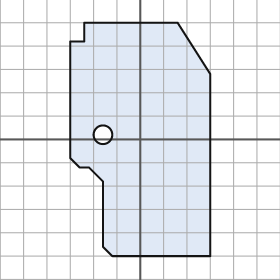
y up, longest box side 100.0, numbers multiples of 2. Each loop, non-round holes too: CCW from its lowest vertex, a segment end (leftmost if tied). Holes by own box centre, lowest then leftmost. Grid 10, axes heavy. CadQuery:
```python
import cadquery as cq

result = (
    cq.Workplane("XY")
    .moveTo(-12.0, -50.0)
    .lineTo(30.0, -50.0)
    .lineTo(30.0, 28.0)
    .lineTo(16.0, 50.0)
    .lineTo(-24.0, 50.0)
    .lineTo(-24.0, 42.0)
    .lineTo(-30.0, 42.0)
    .lineTo(-30.0, -8.0)
    .lineTo(-26.0, -12.0)
    .lineTo(-22.0, -12.0)
    .lineTo(-16.0, -18.0)
    .lineTo(-16.0, -46.0)
    .close()
    .moveTo(-16.0, 2.0)
    .circle(4.0)
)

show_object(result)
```